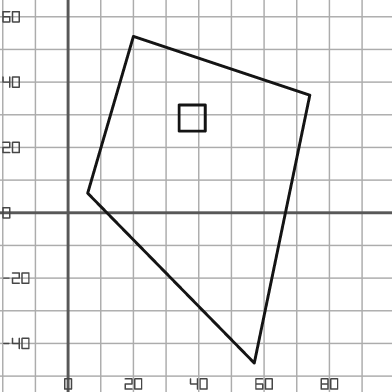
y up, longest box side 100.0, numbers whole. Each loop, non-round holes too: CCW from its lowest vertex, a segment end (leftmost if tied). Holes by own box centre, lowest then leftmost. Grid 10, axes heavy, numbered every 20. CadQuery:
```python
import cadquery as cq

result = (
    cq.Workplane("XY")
    .moveTo(57.0, -46.0)
    .lineTo(74.0, 36.0)
    .lineTo(20.0, 54.0)
    .lineTo(6.0, 6.0)
    .close()
    .moveTo(34.0, 25.0)
    .lineTo(42.0, 25.0)
    .lineTo(42.0, 33.0)
    .lineTo(34.0, 33.0)
    .close()
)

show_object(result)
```